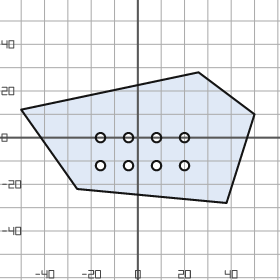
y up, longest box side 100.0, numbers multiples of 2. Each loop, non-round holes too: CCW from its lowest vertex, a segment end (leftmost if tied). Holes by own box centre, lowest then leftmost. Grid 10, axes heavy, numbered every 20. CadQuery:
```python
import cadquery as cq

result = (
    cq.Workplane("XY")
    .moveTo(38.0, -28.0)
    .lineTo(50.0, 10.0)
    .lineTo(26.0, 28.0)
    .lineTo(-50.0, 12.0)
    .lineTo(-26.0, -22.0)
    .close()
    .moveTo(-16.0, -12.0)
    .circle(2.0)
    .moveTo(-4.0, -12.0)
    .circle(2.0)
    .moveTo(8.0, -12.0)
    .circle(2.0)
    .moveTo(20.0, -12.0)
    .circle(2.0)
    .moveTo(-16.0, 0.0)
    .circle(2.0)
    .moveTo(-4.0, 0.0)
    .circle(2.0)
    .moveTo(8.0, 0.0)
    .circle(2.0)
    .moveTo(20.0, 0.0)
    .circle(2.0)
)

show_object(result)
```